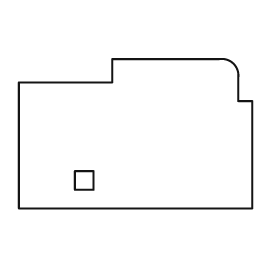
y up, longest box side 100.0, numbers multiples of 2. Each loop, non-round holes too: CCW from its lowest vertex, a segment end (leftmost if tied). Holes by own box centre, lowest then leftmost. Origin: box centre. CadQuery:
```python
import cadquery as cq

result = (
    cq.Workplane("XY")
    .moveTo(-50.0, -32.0)
    .lineTo(50.0, -32.0)
    .lineTo(50.0, 14.0)
    .lineTo(44.0, 14.0)
    .lineTo(44.0, 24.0)
    .threePointArc((42.0, 30.0), (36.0, 32.0))
    .lineTo(-10.0, 32.0)
    .lineTo(-10.0, 22.0)
    .lineTo(-50.0, 22.0)
    .close()
    .moveTo(-26.0, -24.0)
    .lineTo(-18.0, -24.0)
    .lineTo(-18.0, -16.0)
    .lineTo(-26.0, -16.0)
    .close()
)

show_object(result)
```